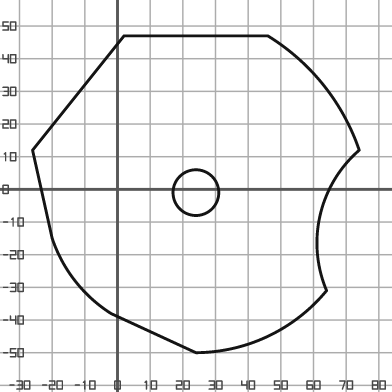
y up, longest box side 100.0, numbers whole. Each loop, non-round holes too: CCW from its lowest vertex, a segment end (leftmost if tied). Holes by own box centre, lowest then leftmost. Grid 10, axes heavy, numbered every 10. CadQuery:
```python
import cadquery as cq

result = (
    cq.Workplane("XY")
    .moveTo(24.0, -50.0)
    .threePointArc((46.0, -45.0), (64.0, -31.0))
    .threePointArc((62.0, -8.0), (74.0, 12.0))
    .threePointArc((63.0, 32.0), (46.0, 47.0))
    .lineTo(2.0, 47.0)
    .lineTo(-26.0, 12.0)
    .lineTo(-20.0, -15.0)
    .threePointArc((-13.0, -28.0), (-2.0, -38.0))
    .close()
    .moveTo(24.0, -1.0)
    .circle(7.0)
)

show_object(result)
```